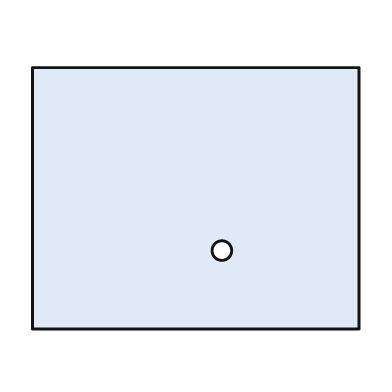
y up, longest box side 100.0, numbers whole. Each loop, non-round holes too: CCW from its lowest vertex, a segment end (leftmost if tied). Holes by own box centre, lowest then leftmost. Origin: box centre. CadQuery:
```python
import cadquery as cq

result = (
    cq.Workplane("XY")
    .moveTo(-50.0, -40.0)
    .lineTo(50.0, -40.0)
    .lineTo(50.0, 40.0)
    .lineTo(-50.0, 40.0)
    .close()
    .moveTo(8.0, -16.0)
    .circle(3.0)
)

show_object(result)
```